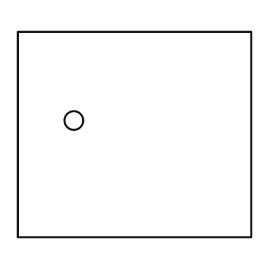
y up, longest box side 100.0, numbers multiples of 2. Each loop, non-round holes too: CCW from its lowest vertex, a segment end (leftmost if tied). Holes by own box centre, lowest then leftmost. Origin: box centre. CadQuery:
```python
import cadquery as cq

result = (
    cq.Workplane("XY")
    .moveTo(-50.0, -44.0)
    .lineTo(50.0, -44.0)
    .lineTo(50.0, 44.0)
    .lineTo(-50.0, 44.0)
    .close()
    .moveTo(-26.0, 6.0)
    .circle(4.0)
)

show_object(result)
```